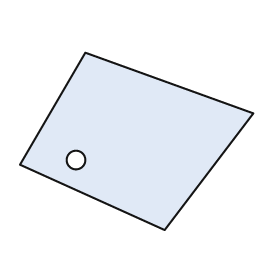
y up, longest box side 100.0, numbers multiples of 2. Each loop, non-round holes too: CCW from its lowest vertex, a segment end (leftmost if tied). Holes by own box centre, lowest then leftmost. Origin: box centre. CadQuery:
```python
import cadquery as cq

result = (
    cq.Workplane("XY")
    .moveTo(12.0, -38.0)
    .lineTo(50.0, 12.0)
    .lineTo(-22.0, 38.0)
    .lineTo(-50.0, -10.0)
    .close()
    .moveTo(-26.0, -8.0)
    .circle(4.0)
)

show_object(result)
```